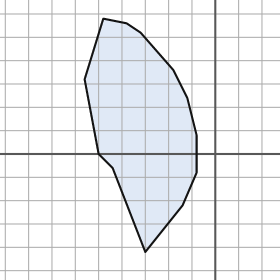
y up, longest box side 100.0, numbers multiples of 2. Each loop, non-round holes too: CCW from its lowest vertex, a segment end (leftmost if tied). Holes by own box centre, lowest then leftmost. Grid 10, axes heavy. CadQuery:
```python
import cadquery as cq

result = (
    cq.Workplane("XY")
    .moveTo(-30.0, -42.0)
    .lineTo(-14.0, -22.0)
    .lineTo(-8.0, -8.0)
    .lineTo(-8.0, 8.0)
    .lineTo(-12.0, 24.0)
    .lineTo(-18.0, 36.0)
    .lineTo(-32.0, 52.0)
    .lineTo(-38.0, 56.0)
    .lineTo(-48.0, 58.0)
    .lineTo(-56.0, 32.0)
    .lineTo(-50.0, 0.0)
    .lineTo(-44.0, -6.0)
    .close()
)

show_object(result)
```